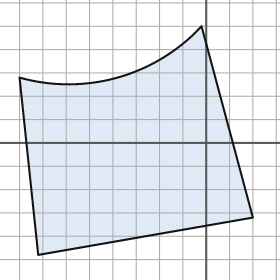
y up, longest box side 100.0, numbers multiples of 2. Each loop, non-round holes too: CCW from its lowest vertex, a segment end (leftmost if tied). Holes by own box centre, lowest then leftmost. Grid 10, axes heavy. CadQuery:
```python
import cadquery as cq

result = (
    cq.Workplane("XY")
    .moveTo(-72.0, -48.0)
    .lineTo(20.0, -32.0)
    .lineTo(-2.0, 50.0)
    .threePointArc((-38.0, 28.0), (-80.0, 28.0))
    .close()
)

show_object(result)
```